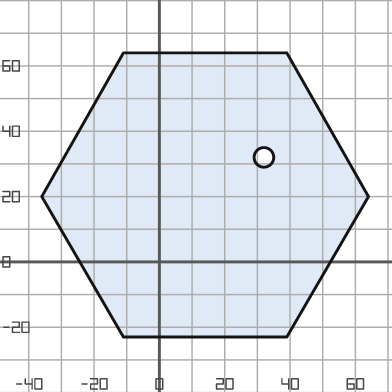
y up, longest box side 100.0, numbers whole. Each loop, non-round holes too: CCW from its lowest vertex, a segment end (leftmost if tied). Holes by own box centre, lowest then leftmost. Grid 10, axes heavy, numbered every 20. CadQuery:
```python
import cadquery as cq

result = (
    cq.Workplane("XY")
    .moveTo(-11.0, -23.0)
    .lineTo(39.0, -23.0)
    .lineTo(64.0, 20.0)
    .lineTo(39.0, 64.0)
    .lineTo(-11.0, 64.0)
    .lineTo(-36.0, 20.0)
    .close()
    .moveTo(32.0, 32.0)
    .circle(3.0)
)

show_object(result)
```